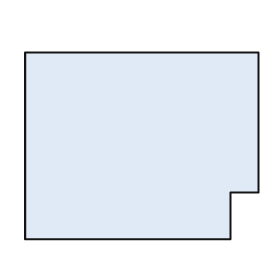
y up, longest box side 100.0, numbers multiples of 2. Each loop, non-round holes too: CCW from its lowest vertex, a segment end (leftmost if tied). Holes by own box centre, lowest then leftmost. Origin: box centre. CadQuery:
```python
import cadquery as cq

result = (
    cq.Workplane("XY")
    .moveTo(-50.0, -40.0)
    .lineTo(38.0, -40.0)
    .lineTo(38.0, -20.0)
    .lineTo(50.0, -20.0)
    .lineTo(50.0, 40.0)
    .lineTo(-50.0, 40.0)
    .close()
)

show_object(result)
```